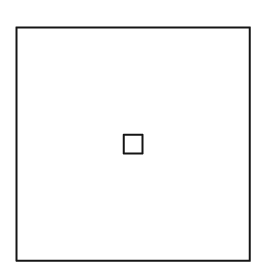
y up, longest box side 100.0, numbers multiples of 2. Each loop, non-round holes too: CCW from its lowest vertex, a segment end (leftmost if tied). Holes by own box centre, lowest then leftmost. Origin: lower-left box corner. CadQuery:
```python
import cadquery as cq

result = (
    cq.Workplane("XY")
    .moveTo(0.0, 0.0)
    .lineTo(100.0, 0.0)
    .lineTo(100.0, 100.0)
    .lineTo(0.0, 100.0)
    .close()
    .moveTo(46.0, 46.0)
    .lineTo(54.0, 46.0)
    .lineTo(54.0, 54.0)
    .lineTo(46.0, 54.0)
    .close()
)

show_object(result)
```